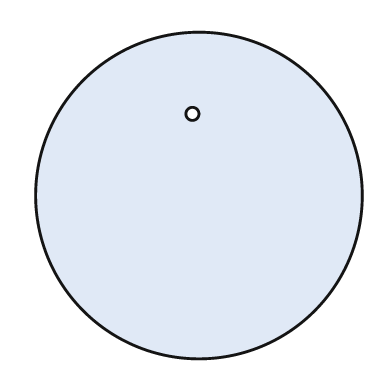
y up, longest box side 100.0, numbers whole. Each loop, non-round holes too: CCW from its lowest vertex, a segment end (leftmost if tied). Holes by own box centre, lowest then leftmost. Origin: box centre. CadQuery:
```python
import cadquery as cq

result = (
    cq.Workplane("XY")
    .moveTo(0.0, 0.0)
    .circle(50.0)
    .moveTo(-2.0, 25.0)
    .circle(2.0)
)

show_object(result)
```